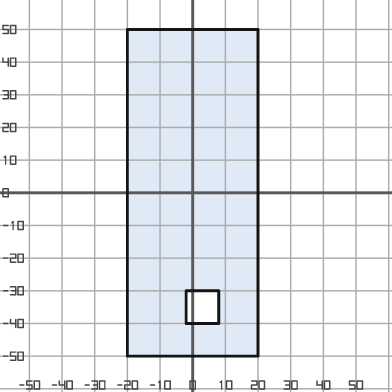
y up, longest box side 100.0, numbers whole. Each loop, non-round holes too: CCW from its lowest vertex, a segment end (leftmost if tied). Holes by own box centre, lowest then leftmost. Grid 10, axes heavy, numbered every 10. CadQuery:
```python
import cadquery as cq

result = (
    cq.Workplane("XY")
    .moveTo(-20.0, -50.0)
    .lineTo(20.0, -50.0)
    .lineTo(20.0, 50.0)
    .lineTo(-20.0, 50.0)
    .close()
    .moveTo(-2.0, -40.0)
    .lineTo(8.0, -40.0)
    .lineTo(8.0, -30.0)
    .lineTo(-2.0, -30.0)
    .close()
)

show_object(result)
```